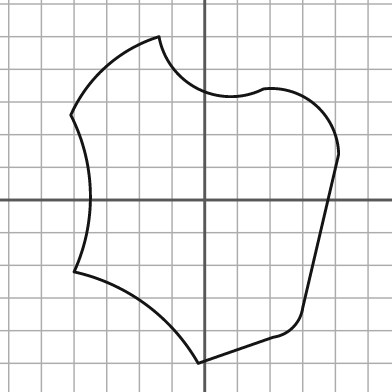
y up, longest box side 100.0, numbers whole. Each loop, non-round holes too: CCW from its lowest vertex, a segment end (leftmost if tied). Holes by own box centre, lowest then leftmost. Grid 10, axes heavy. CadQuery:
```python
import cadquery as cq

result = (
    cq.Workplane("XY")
    .moveTo(-2.0, -50.0)
    .lineTo(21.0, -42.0)
    .threePointArc((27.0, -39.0), (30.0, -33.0))
    .lineTo(41.0, 14.0)
    .threePointArc((34.0, 29.0), (18.0, 34.0))
    .threePointArc((-2.0, 34.0), (-14.0, 50.0))
    .threePointArc((-30.0, 41.0), (-41.0, 26.0))
    .threePointArc((-35.0, 2.0), (-40.0, -22.0))
    .threePointArc((-18.0, -32.0), (-2.0, -50.0))
    .close()
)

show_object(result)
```